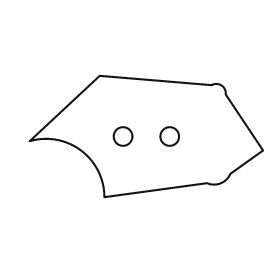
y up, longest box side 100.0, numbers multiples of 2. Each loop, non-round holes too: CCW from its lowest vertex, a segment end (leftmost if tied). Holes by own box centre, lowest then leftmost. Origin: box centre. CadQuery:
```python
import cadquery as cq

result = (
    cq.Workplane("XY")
    .moveTo(-18.0, -26.0)
    .lineTo(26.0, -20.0)
    .threePointArc((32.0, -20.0), (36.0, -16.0))
    .lineTo(50.0, -6.0)
    .lineTo(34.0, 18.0)
    .threePointArc((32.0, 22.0), (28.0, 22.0))
    .lineTo(-20.0, 26.0)
    .lineTo(-50.0, -2.0)
    .threePointArc((-28.0, -6.0), (-18.0, -26.0))
    .close()
    .moveTo(-10.0, 0.0)
    .circle(4.0)
    .moveTo(10.0, 0.0)
    .circle(4.0)
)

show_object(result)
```